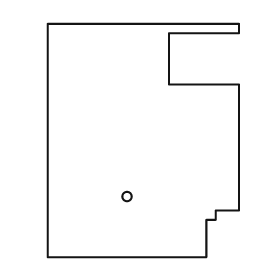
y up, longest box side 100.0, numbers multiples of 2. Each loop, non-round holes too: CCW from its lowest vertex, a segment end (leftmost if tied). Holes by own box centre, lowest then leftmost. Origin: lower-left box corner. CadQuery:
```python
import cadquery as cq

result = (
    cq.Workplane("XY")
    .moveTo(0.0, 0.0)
    .lineTo(68.0, 0.0)
    .lineTo(68.0, 16.0)
    .lineTo(72.0, 16.0)
    .lineTo(72.0, 20.0)
    .lineTo(82.0, 20.0)
    .lineTo(82.0, 74.0)
    .lineTo(52.0, 74.0)
    .lineTo(52.0, 96.0)
    .lineTo(82.0, 96.0)
    .lineTo(82.0, 100.0)
    .lineTo(0.0, 100.0)
    .close()
    .moveTo(34.0, 26.0)
    .circle(2.0)
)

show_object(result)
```